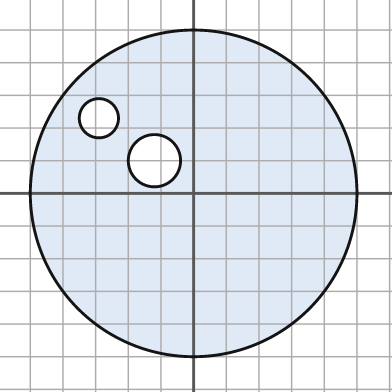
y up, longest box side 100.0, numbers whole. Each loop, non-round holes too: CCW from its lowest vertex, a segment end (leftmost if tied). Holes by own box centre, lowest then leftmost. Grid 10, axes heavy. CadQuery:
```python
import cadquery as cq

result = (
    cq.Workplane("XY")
    .moveTo(0.0, 0.0)
    .circle(50.0)
    .moveTo(-12.0, 10.0)
    .circle(8.0)
    .moveTo(-29.0, 23.0)
    .circle(6.0)
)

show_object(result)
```